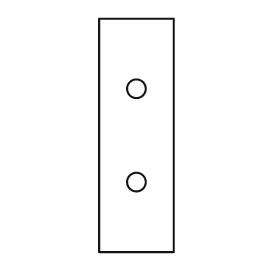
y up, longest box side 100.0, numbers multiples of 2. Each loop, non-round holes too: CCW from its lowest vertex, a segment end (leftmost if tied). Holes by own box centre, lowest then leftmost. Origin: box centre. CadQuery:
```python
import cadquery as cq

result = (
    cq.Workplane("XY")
    .moveTo(-16.0, -50.0)
    .lineTo(16.0, -50.0)
    .lineTo(16.0, 50.0)
    .lineTo(-16.0, 50.0)
    .close()
    .moveTo(0.0, -20.0)
    .circle(4.0)
    .moveTo(0.0, 20.0)
    .circle(4.0)
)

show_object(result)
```